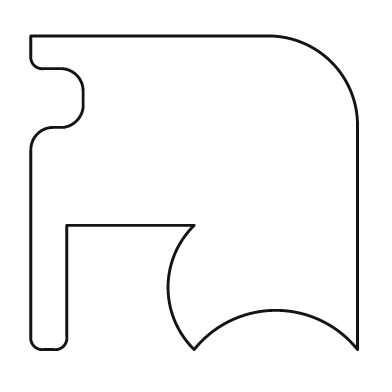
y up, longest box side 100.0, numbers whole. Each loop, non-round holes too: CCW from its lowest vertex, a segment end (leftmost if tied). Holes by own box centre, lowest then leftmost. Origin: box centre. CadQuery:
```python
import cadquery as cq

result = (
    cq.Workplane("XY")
    .moveTo(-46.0, -48.0)
    .lineTo(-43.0, -48.0)
    .threePointArc((-40.0, -47.0), (-39.0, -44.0))
    .lineTo(-39.0, -10.0)
    .lineTo(0.0, -10.0)
    .threePointArc((-8.0, -29.0), (0.0, -48.0))
    .threePointArc((25.0, -36.0), (50.0, -48.0))
    .lineTo(50.0, 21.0)
    .threePointArc((42.0, 40.0), (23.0, 48.0))
    .lineTo(-50.0, 48.0)
    .lineTo(-50.0, 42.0)
    .threePointArc((-49.0, 39.0), (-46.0, 38.0))
    .lineTo(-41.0, 38.0)
    .threePointArc((-36.0, 36.0), (-34.0, 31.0))
    .lineTo(-34.0, 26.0)
    .threePointArc((-36.0, 22.0), (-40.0, 20.0))
    .lineTo(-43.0, 20.0)
    .threePointArc((-48.0, 18.0), (-50.0, 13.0))
    .lineTo(-50.0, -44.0)
    .threePointArc((-49.0, -47.0), (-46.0, -48.0))
    .close()
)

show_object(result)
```